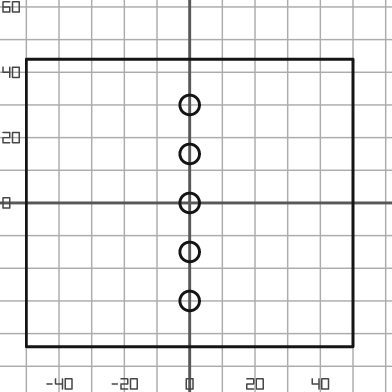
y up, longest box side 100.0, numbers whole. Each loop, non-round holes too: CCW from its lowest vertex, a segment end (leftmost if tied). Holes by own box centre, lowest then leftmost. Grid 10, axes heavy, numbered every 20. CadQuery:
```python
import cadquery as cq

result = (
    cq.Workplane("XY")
    .moveTo(-50.0, -44.0)
    .lineTo(50.0, -44.0)
    .lineTo(50.0, 44.0)
    .lineTo(-50.0, 44.0)
    .close()
    .moveTo(0.0, -30.0)
    .circle(3.0)
    .moveTo(0.0, -15.0)
    .circle(3.0)
    .moveTo(0.0, 0.0)
    .circle(3.0)
    .moveTo(0.0, 15.0)
    .circle(3.0)
    .moveTo(0.0, 30.0)
    .circle(3.0)
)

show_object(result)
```